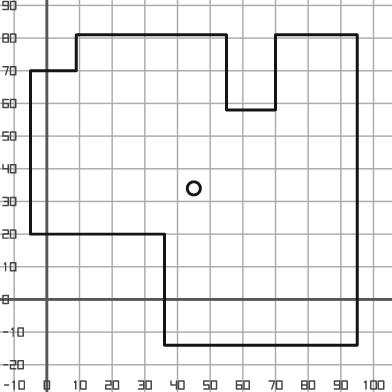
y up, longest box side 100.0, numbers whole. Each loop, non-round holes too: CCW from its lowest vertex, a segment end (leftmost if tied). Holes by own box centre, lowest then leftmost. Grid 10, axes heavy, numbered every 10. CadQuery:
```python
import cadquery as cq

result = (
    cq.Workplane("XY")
    .moveTo(36.0, -14.0)
    .lineTo(95.0, -14.0)
    .lineTo(95.0, 81.0)
    .lineTo(70.0, 81.0)
    .lineTo(70.0, 58.0)
    .lineTo(55.0, 58.0)
    .lineTo(55.0, 81.0)
    .lineTo(9.0, 81.0)
    .lineTo(9.0, 70.0)
    .lineTo(-5.0, 70.0)
    .lineTo(-5.0, 20.0)
    .lineTo(36.0, 20.0)
    .close()
    .moveTo(45.0, 34.0)
    .circle(2.0)
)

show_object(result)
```